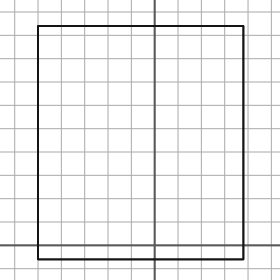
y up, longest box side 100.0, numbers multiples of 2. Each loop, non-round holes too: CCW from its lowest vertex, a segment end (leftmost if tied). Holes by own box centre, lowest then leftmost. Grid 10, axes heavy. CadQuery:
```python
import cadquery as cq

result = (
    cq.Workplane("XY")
    .moveTo(-50.0, -6.0)
    .lineTo(38.0, -6.0)
    .lineTo(38.0, 94.0)
    .lineTo(-50.0, 94.0)
    .close()
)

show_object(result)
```